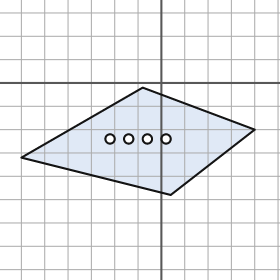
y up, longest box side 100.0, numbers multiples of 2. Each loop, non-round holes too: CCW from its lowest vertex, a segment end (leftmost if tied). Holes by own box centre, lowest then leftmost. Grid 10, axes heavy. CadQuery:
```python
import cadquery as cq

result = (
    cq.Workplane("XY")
    .moveTo(4.0, -48.0)
    .lineTo(40.0, -20.0)
    .lineTo(-8.0, -2.0)
    .lineTo(-60.0, -32.0)
    .close()
    .moveTo(-22.0, -24.0)
    .circle(2.0)
    .moveTo(-14.0, -24.0)
    .circle(2.0)
    .moveTo(-6.0, -24.0)
    .circle(2.0)
    .moveTo(2.0, -24.0)
    .circle(2.0)
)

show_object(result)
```